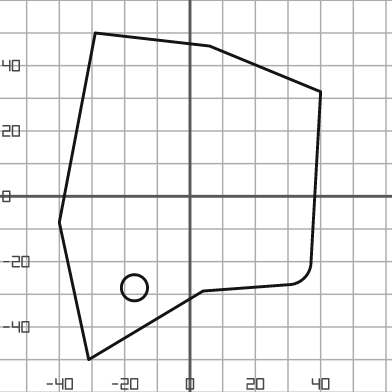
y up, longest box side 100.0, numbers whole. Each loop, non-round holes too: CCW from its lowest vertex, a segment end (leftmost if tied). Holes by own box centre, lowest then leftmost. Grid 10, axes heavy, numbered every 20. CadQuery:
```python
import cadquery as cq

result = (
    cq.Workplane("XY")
    .moveTo(-31.0, -50.0)
    .lineTo(4.0, -29.0)
    .lineTo(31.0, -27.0)
    .threePointArc((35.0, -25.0), (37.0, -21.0))
    .lineTo(40.0, 32.0)
    .lineTo(6.0, 46.0)
    .lineTo(-29.0, 50.0)
    .lineTo(-40.0, -8.0)
    .close()
    .moveTo(-17.0, -28.0)
    .circle(4.0)
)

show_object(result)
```